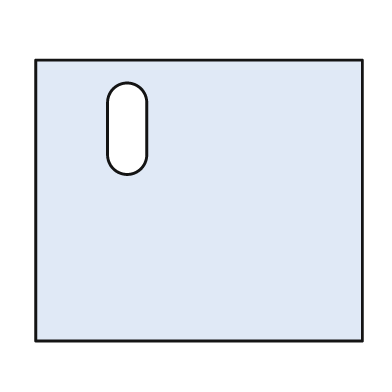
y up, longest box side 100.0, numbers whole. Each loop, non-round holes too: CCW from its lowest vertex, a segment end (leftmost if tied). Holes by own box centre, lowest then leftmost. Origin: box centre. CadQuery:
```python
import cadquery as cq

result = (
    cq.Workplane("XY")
    .moveTo(-50.0, -43.0)
    .lineTo(50.0, -43.0)
    .lineTo(50.0, 43.0)
    .lineTo(-50.0, 43.0)
    .close()
    .moveTo(-28.0, 14.0)
    .threePointArc((-22.0, 8.0), (-16.0, 14.0))
    .lineTo(-16.0, 30.0)
    .threePointArc((-22.0, 36.0), (-28.0, 30.0))
    .close()
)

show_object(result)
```